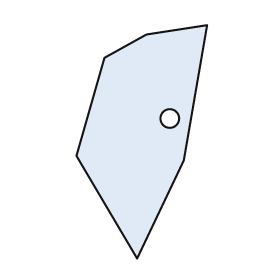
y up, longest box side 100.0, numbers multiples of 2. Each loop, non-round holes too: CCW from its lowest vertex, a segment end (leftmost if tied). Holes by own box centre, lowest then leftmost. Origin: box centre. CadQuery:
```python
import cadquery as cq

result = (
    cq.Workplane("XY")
    .moveTo(-2.0, -50.0)
    .lineTo(18.0, -8.0)
    .lineTo(28.0, 50.0)
    .lineTo(2.0, 46.0)
    .lineTo(-16.0, 36.0)
    .lineTo(-28.0, -6.0)
    .close()
    .moveTo(12.0, 10.0)
    .circle(4.0)
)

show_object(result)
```